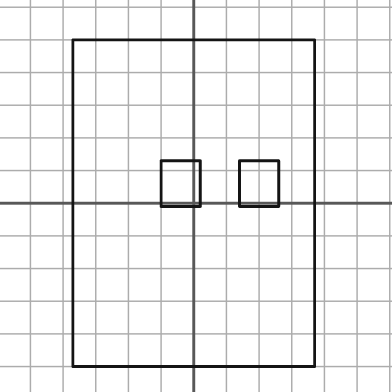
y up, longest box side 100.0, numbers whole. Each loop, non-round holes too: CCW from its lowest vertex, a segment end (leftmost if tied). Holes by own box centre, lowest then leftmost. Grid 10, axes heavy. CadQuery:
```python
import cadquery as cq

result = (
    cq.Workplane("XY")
    .moveTo(-37.0, -50.0)
    .lineTo(37.0, -50.0)
    .lineTo(37.0, 50.0)
    .lineTo(-37.0, 50.0)
    .close()
    .moveTo(-10.0, -1.0)
    .lineTo(2.0, -1.0)
    .lineTo(2.0, 13.0)
    .lineTo(-10.0, 13.0)
    .close()
    .moveTo(14.0, -1.0)
    .lineTo(26.0, -1.0)
    .lineTo(26.0, 13.0)
    .lineTo(14.0, 13.0)
    .close()
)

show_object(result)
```